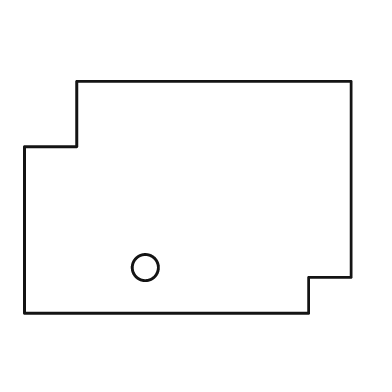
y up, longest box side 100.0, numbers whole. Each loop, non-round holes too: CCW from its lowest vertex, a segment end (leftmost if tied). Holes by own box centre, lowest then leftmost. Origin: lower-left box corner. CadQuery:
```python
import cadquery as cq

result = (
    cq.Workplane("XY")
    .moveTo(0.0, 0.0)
    .lineTo(87.0, 0.0)
    .lineTo(87.0, 11.0)
    .lineTo(100.0, 11.0)
    .lineTo(100.0, 71.0)
    .lineTo(16.0, 71.0)
    .lineTo(16.0, 51.0)
    .lineTo(0.0, 51.0)
    .close()
    .moveTo(37.0, 14.0)
    .circle(4.0)
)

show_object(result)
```